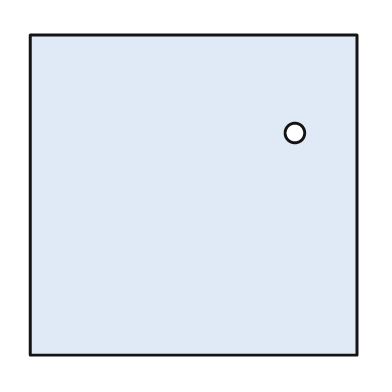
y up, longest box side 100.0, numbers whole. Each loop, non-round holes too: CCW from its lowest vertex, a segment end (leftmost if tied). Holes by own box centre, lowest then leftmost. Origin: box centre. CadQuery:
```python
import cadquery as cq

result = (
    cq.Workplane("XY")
    .moveTo(-50.0, -49.0)
    .lineTo(50.0, -49.0)
    .lineTo(50.0, 49.0)
    .lineTo(-50.0, 49.0)
    .close()
    .moveTo(31.0, 19.0)
    .circle(3.0)
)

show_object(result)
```